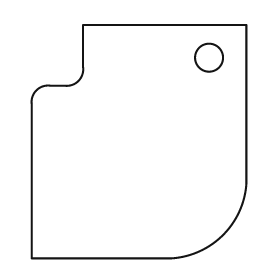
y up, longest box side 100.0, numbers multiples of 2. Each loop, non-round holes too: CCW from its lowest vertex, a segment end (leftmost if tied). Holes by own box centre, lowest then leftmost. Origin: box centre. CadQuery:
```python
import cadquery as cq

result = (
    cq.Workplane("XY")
    .moveTo(-46.0, -50.0)
    .lineTo(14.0, -50.0)
    .threePointArc((36.0, -40.0), (46.0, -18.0))
    .lineTo(46.0, 50.0)
    .lineTo(-24.0, 50.0)
    .lineTo(-24.0, 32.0)
    .threePointArc((-26.0, 26.0), (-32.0, 24.0))
    .lineTo(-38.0, 24.0)
    .threePointArc((-44.0, 22.0), (-46.0, 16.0))
    .close()
    .moveTo(30.0, 36.0)
    .circle(6.0)
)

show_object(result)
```